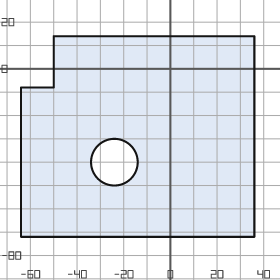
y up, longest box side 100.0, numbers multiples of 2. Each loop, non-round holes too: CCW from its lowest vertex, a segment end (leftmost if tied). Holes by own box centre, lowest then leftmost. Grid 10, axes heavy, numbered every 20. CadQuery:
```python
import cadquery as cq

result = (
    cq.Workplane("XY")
    .moveTo(-64.0, -72.0)
    .lineTo(36.0, -72.0)
    .lineTo(36.0, 14.0)
    .lineTo(-50.0, 14.0)
    .lineTo(-50.0, -8.0)
    .lineTo(-64.0, -8.0)
    .close()
    .moveTo(-24.0, -40.0)
    .circle(10.0)
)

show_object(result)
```